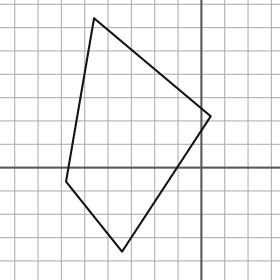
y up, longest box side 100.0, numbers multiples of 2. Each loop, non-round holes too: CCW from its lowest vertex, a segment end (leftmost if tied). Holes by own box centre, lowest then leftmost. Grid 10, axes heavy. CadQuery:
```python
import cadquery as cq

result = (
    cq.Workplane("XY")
    .moveTo(-34.0, -36.0)
    .lineTo(4.0, 22.0)
    .lineTo(-46.0, 64.0)
    .lineTo(-58.0, -6.0)
    .close()
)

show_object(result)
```